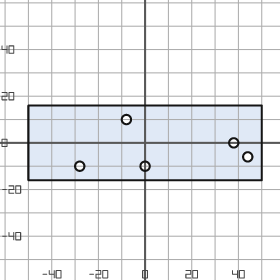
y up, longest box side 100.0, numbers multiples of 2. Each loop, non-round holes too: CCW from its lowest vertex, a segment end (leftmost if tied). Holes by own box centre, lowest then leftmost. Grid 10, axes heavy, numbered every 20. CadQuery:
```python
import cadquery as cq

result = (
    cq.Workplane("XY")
    .moveTo(-50.0, -16.0)
    .lineTo(50.0, -16.0)
    .lineTo(50.0, 16.0)
    .lineTo(-50.0, 16.0)
    .close()
    .moveTo(-28.0, -10.0)
    .circle(2.0)
    .moveTo(0.0, -10.0)
    .circle(2.0)
    .moveTo(44.0, -6.0)
    .circle(2.0)
    .moveTo(38.0, 0.0)
    .circle(2.0)
    .moveTo(-8.0, 10.0)
    .circle(2.0)
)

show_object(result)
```